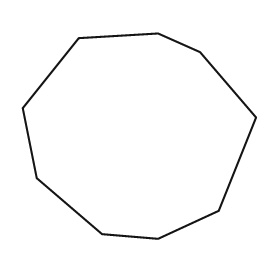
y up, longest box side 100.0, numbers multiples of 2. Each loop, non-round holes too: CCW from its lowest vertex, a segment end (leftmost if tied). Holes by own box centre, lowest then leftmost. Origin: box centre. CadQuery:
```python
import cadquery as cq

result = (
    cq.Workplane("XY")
    .moveTo(8.0, -44.0)
    .lineTo(34.0, -32.0)
    .lineTo(50.0, 8.0)
    .lineTo(26.0, 36.0)
    .lineTo(8.0, 44.0)
    .lineTo(-26.0, 42.0)
    .lineTo(-50.0, 12.0)
    .lineTo(-44.0, -18.0)
    .lineTo(-16.0, -42.0)
    .close()
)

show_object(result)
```